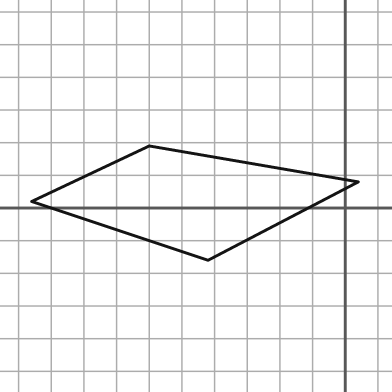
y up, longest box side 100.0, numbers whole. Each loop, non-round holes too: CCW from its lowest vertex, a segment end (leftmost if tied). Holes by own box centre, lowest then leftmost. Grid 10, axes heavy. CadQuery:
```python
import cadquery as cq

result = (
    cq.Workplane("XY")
    .moveTo(-42.0, -16.0)
    .lineTo(4.0, 8.0)
    .lineTo(-60.0, 19.0)
    .lineTo(-96.0, 2.0)
    .close()
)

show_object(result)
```